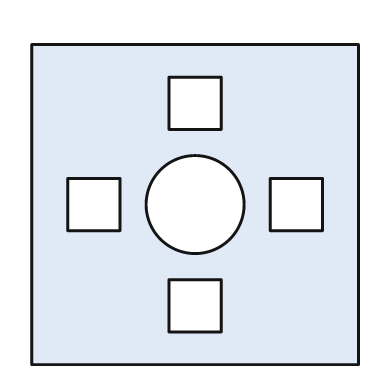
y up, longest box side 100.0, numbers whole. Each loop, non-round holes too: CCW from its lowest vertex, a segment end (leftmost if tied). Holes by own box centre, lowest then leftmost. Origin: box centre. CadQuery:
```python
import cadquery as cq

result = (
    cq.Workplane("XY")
    .moveTo(-50.0, -49.0)
    .lineTo(50.0, -49.0)
    .lineTo(50.0, 49.0)
    .lineTo(-50.0, 49.0)
    .close()
    .moveTo(-8.0, -39.0)
    .lineTo(8.0, -39.0)
    .lineTo(8.0, -23.0)
    .lineTo(-8.0, -23.0)
    .close()
    .moveTo(-39.0, -8.0)
    .lineTo(-23.0, -8.0)
    .lineTo(-23.0, 8.0)
    .lineTo(-39.0, 8.0)
    .close()
    .moveTo(0.0, 0.0)
    .circle(15.0)
    .moveTo(23.0, -8.0)
    .lineTo(39.0, -8.0)
    .lineTo(39.0, 8.0)
    .lineTo(23.0, 8.0)
    .close()
    .moveTo(-8.0, 23.0)
    .lineTo(8.0, 23.0)
    .lineTo(8.0, 39.0)
    .lineTo(-8.0, 39.0)
    .close()
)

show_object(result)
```